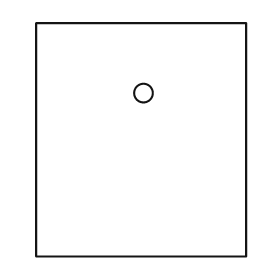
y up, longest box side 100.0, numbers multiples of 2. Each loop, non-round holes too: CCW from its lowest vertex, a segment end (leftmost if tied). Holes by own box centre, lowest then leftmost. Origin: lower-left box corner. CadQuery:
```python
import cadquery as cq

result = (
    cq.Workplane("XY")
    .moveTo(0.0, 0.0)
    .lineTo(90.0, 0.0)
    .lineTo(90.0, 100.0)
    .lineTo(0.0, 100.0)
    .close()
    .moveTo(46.0, 70.0)
    .circle(4.0)
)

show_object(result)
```